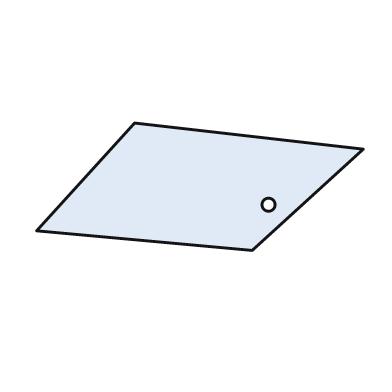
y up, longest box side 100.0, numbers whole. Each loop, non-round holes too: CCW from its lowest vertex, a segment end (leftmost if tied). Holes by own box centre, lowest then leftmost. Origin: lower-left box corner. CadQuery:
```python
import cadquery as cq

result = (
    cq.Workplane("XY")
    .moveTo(66.0, 0.0)
    .lineTo(100.0, 31.0)
    .lineTo(30.0, 39.0)
    .lineTo(0.0, 6.0)
    .close()
    .moveTo(71.0, 14.0)
    .circle(2.0)
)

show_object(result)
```